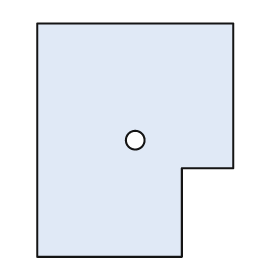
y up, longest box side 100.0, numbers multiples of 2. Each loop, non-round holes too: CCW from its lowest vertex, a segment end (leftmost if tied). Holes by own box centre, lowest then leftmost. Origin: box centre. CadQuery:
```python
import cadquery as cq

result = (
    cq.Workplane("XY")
    .moveTo(-42.0, -50.0)
    .lineTo(20.0, -50.0)
    .lineTo(20.0, -12.0)
    .lineTo(42.0, -12.0)
    .lineTo(42.0, 50.0)
    .lineTo(-42.0, 50.0)
    .close()
    .moveTo(0.0, 0.0)
    .circle(4.0)
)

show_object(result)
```